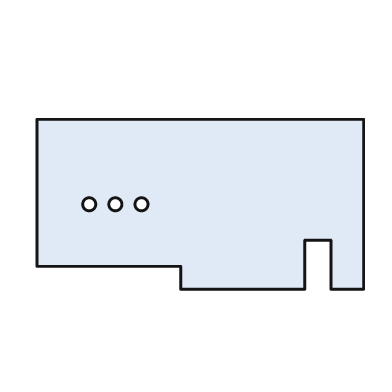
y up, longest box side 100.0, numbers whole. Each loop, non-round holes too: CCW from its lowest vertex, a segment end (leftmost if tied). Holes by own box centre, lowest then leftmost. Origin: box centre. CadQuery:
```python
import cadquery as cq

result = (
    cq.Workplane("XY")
    .moveTo(-6.0, -26.0)
    .lineTo(32.0, -26.0)
    .lineTo(32.0, -11.0)
    .lineTo(40.0, -11.0)
    .lineTo(40.0, -26.0)
    .lineTo(50.0, -26.0)
    .lineTo(50.0, 26.0)
    .lineTo(-50.0, 26.0)
    .lineTo(-50.0, -19.0)
    .lineTo(-6.0, -19.0)
    .close()
    .moveTo(-34.0, 0.0)
    .circle(2.0)
    .moveTo(-26.0, 0.0)
    .circle(2.0)
    .moveTo(-18.0, 0.0)
    .circle(2.0)
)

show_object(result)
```